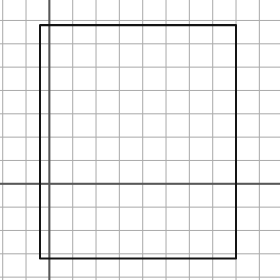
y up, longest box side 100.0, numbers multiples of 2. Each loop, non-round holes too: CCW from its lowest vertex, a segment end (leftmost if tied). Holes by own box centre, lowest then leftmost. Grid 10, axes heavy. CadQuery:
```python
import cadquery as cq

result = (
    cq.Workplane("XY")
    .moveTo(-4.0, -32.0)
    .lineTo(80.0, -32.0)
    .lineTo(80.0, 68.0)
    .lineTo(-4.0, 68.0)
    .close()
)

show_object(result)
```